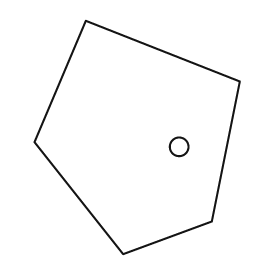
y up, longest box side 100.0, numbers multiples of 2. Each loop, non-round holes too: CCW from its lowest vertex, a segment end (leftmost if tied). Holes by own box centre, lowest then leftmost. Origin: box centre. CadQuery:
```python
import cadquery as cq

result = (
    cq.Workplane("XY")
    .moveTo(-6.0, -50.0)
    .lineTo(32.0, -36.0)
    .lineTo(44.0, 24.0)
    .lineTo(-22.0, 50.0)
    .lineTo(-44.0, -2.0)
    .close()
    .moveTo(18.0, -4.0)
    .circle(4.0)
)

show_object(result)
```